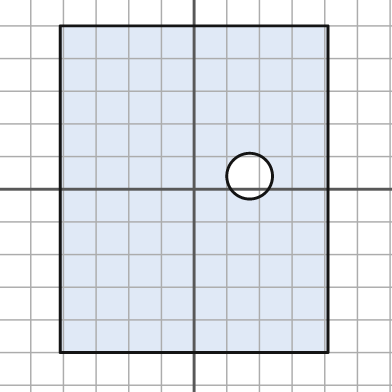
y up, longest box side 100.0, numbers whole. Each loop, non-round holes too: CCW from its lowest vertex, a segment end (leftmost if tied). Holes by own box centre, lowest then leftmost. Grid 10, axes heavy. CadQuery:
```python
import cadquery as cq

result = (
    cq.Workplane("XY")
    .moveTo(-41.0, -50.0)
    .lineTo(41.0, -50.0)
    .lineTo(41.0, 50.0)
    .lineTo(-41.0, 50.0)
    .close()
    .moveTo(17.0, 4.0)
    .circle(7.0)
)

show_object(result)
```